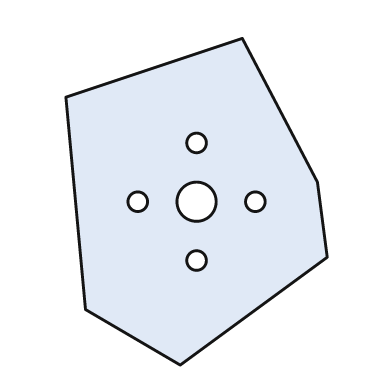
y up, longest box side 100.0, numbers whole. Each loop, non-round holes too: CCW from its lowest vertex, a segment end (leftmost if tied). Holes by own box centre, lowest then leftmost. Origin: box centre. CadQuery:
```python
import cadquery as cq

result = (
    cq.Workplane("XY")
    .moveTo(-5.0, -50.0)
    .lineTo(40.0, -17.0)
    .lineTo(37.0, 6.0)
    .lineTo(14.0, 50.0)
    .lineTo(-40.0, 32.0)
    .lineTo(-34.0, -33.0)
    .close()
    .moveTo(0.0, -18.0)
    .circle(3.0)
    .moveTo(-18.0, 0.0)
    .circle(3.0)
    .moveTo(0.0, 0.0)
    .circle(6.0)
    .moveTo(18.0, 0.0)
    .circle(3.0)
    .moveTo(0.0, 18.0)
    .circle(3.0)
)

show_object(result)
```